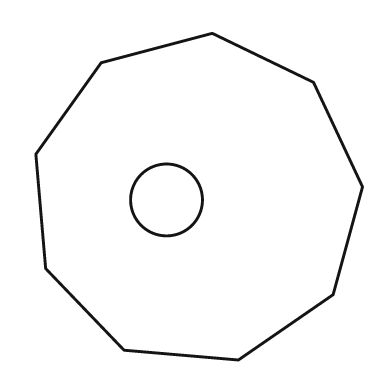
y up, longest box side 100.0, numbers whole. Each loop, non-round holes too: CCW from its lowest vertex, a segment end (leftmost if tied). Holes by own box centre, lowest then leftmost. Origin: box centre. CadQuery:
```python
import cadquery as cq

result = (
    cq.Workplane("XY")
    .moveTo(12.0, -50.0)
    .lineTo(41.0, -30.0)
    .lineTo(50.0, 3.0)
    .lineTo(35.0, 35.0)
    .lineTo(4.0, 50.0)
    .lineTo(-30.0, 41.0)
    .lineTo(-50.0, 13.0)
    .lineTo(-47.0, -22.0)
    .lineTo(-23.0, -47.0)
    .close()
    .moveTo(-10.0, -1.0)
    .circle(11.0)
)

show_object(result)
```